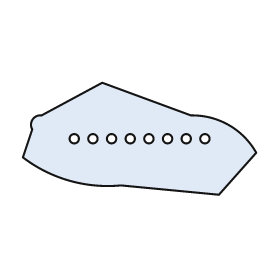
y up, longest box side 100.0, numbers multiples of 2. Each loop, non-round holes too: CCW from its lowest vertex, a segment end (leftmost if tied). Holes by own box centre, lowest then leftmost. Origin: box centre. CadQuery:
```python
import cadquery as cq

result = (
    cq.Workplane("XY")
    .moveTo(34.0, -24.0)
    .lineTo(50.0, -6.0)
    .threePointArc((38.0, 6.0), (22.0, 10.0))
    .lineTo(-16.0, 24.0)
    .lineTo(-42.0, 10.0)
    .threePointArc((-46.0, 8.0), (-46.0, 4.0))
    .lineTo(-50.0, -8.0)
    .threePointArc((-30.0, -18.0), (-8.0, -20.0))
    .close()
    .moveTo(-28.0, 0.0)
    .circle(2.0)
    .moveTo(-20.0, 0.0)
    .circle(2.0)
    .moveTo(-12.0, 0.0)
    .circle(2.0)
    .moveTo(-4.0, 0.0)
    .circle(2.0)
    .moveTo(4.0, 0.0)
    .circle(2.0)
    .moveTo(12.0, 0.0)
    .circle(2.0)
    .moveTo(20.0, 0.0)
    .circle(2.0)
    .moveTo(28.0, 0.0)
    .circle(2.0)
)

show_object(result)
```